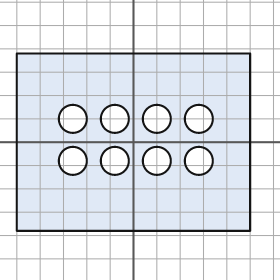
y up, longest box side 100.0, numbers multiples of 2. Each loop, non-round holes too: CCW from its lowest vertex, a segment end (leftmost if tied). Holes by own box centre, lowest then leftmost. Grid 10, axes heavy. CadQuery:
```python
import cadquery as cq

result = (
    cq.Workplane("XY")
    .moveTo(-50.0, -38.0)
    .lineTo(50.0, -38.0)
    .lineTo(50.0, 38.0)
    .lineTo(-50.0, 38.0)
    .close()
    .moveTo(-26.0, -8.0)
    .circle(6.0)
    .moveTo(-8.0, -8.0)
    .circle(6.0)
    .moveTo(10.0, -8.0)
    .circle(6.0)
    .moveTo(28.0, -8.0)
    .circle(6.0)
    .moveTo(-26.0, 10.0)
    .circle(6.0)
    .moveTo(-8.0, 10.0)
    .circle(6.0)
    .moveTo(10.0, 10.0)
    .circle(6.0)
    .moveTo(28.0, 10.0)
    .circle(6.0)
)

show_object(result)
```